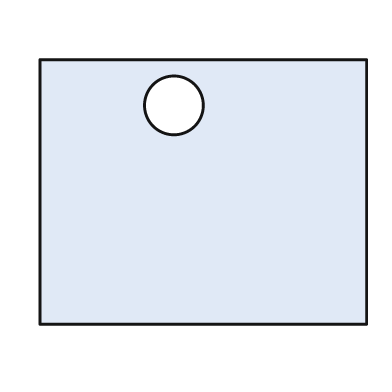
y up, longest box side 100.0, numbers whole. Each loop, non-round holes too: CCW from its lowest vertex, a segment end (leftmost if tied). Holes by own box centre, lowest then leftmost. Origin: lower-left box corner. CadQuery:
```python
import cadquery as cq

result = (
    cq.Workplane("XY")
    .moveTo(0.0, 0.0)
    .lineTo(100.0, 0.0)
    .lineTo(100.0, 81.0)
    .lineTo(0.0, 81.0)
    .close()
    .moveTo(41.0, 67.0)
    .circle(9.0)
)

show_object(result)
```